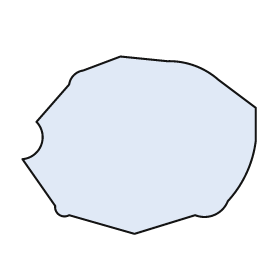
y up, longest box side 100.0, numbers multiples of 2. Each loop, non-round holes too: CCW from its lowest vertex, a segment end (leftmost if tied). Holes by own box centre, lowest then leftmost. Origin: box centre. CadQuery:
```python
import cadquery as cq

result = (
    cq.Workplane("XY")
    .moveTo(-2.0, -38.0)
    .lineTo(24.0, -30.0)
    .threePointArc((32.0, -30.0), (38.0, -24.0))
    .threePointArc((46.0, -12.0), (50.0, 2.0))
    .lineTo(50.0, 16.0)
    .lineTo(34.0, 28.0)
    .threePointArc((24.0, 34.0), (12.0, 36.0))
    .lineTo(-8.0, 38.0)
    .lineTo(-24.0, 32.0)
    .threePointArc((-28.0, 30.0), (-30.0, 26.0))
    .lineTo(-44.0, 10.0)
    .threePointArc((-42.0, 0.0), (-50.0, -6.0))
    .lineTo(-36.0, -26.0)
    .threePointArc((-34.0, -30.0), (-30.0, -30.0))
    .close()
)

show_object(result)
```